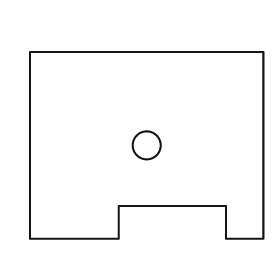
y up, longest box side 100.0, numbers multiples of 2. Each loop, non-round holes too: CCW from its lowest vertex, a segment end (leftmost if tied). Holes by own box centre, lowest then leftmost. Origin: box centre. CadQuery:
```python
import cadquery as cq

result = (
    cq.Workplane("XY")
    .moveTo(-50.0, -40.0)
    .lineTo(-12.0, -40.0)
    .lineTo(-12.0, -26.0)
    .lineTo(34.0, -26.0)
    .lineTo(34.0, -40.0)
    .lineTo(50.0, -40.0)
    .lineTo(50.0, 40.0)
    .lineTo(-50.0, 40.0)
    .close()
    .moveTo(0.0, 0.0)
    .circle(6.0)
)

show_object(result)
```